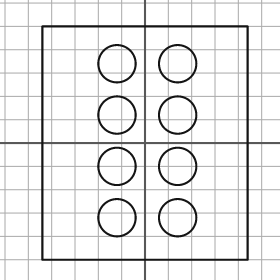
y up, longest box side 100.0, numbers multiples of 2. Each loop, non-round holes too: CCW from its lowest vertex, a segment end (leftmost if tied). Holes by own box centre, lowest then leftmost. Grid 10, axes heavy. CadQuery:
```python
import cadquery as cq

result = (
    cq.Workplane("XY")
    .moveTo(-44.0, -50.0)
    .lineTo(44.0, -50.0)
    .lineTo(44.0, 50.0)
    .lineTo(-44.0, 50.0)
    .close()
    .moveTo(-12.0, -32.0)
    .circle(8.0)
    .moveTo(14.0, -32.0)
    .circle(8.0)
    .moveTo(-12.0, -10.0)
    .circle(8.0)
    .moveTo(14.0, -10.0)
    .circle(8.0)
    .moveTo(-12.0, 12.0)
    .circle(8.0)
    .moveTo(14.0, 12.0)
    .circle(8.0)
    .moveTo(-12.0, 34.0)
    .circle(8.0)
    .moveTo(14.0, 34.0)
    .circle(8.0)
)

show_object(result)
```